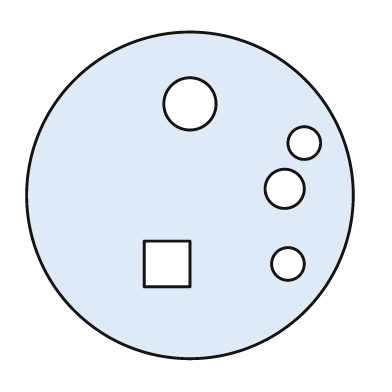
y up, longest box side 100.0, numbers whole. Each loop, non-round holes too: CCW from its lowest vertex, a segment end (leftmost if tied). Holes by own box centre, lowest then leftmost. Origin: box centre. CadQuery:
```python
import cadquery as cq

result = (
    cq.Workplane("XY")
    .moveTo(0.0, 0.0)
    .circle(50.0)
    .moveTo(-14.0, -28.0)
    .lineTo(0.0, -28.0)
    .lineTo(0.0, -14.0)
    .lineTo(-14.0, -14.0)
    .close()
    .moveTo(30.0, -21.0)
    .circle(5.0)
    .moveTo(29.0, 2.0)
    .circle(6.0)
    .moveTo(35.0, 16.0)
    .circle(5.0)
    .moveTo(0.0, 28.0)
    .circle(8.0)
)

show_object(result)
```